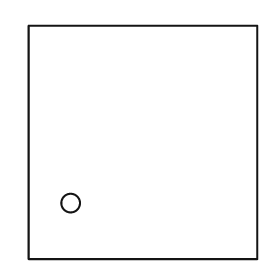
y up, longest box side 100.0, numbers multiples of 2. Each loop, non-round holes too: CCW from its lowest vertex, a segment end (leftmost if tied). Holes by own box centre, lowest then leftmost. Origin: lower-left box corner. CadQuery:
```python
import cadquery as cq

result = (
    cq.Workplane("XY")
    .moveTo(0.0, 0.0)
    .lineTo(98.0, 0.0)
    .lineTo(98.0, 100.0)
    .lineTo(0.0, 100.0)
    .close()
    .moveTo(18.0, 24.0)
    .circle(4.0)
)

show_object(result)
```